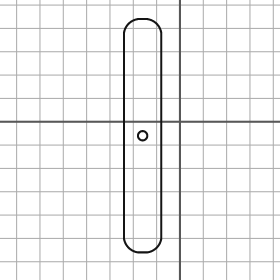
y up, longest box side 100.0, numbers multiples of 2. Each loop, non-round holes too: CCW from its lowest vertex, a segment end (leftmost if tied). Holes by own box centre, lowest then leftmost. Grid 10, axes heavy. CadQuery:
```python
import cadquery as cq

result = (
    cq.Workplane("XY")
    .moveTo(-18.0, -56.0)
    .lineTo(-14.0, -56.0)
    .threePointArc((-10.0, -54.0), (-8.0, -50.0))
    .lineTo(-8.0, 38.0)
    .threePointArc((-10.0, 42.0), (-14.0, 44.0))
    .lineTo(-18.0, 44.0)
    .threePointArc((-22.0, 42.0), (-24.0, 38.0))
    .lineTo(-24.0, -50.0)
    .threePointArc((-22.0, -54.0), (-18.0, -56.0))
    .close()
    .moveTo(-16.0, -6.0)
    .circle(2.0)
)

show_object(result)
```